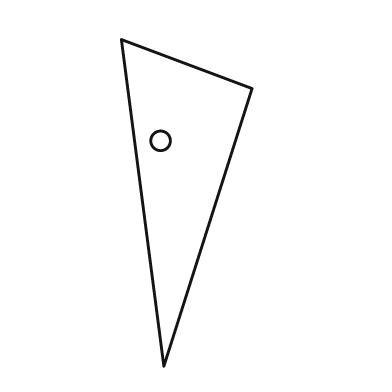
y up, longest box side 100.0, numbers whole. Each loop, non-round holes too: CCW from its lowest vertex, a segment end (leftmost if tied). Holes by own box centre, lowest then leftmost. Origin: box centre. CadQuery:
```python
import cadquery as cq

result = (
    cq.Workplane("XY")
    .moveTo(-7.0, -50.0)
    .lineTo(20.0, 35.0)
    .lineTo(-20.0, 50.0)
    .close()
    .moveTo(-8.0, 19.0)
    .circle(3.0)
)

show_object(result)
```